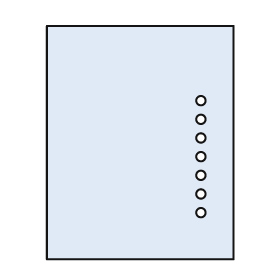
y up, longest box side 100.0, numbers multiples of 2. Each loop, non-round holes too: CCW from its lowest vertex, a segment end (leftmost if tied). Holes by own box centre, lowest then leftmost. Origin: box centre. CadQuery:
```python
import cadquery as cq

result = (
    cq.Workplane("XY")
    .moveTo(-40.0, -50.0)
    .lineTo(40.0, -50.0)
    .lineTo(40.0, 50.0)
    .lineTo(-40.0, 50.0)
    .close()
    .moveTo(26.0, -30.0)
    .circle(2.0)
    .moveTo(26.0, -22.0)
    .circle(2.0)
    .moveTo(26.0, -14.0)
    .circle(2.0)
    .moveTo(26.0, -6.0)
    .circle(2.0)
    .moveTo(26.0, 2.0)
    .circle(2.0)
    .moveTo(26.0, 10.0)
    .circle(2.0)
    .moveTo(26.0, 18.0)
    .circle(2.0)
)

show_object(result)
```